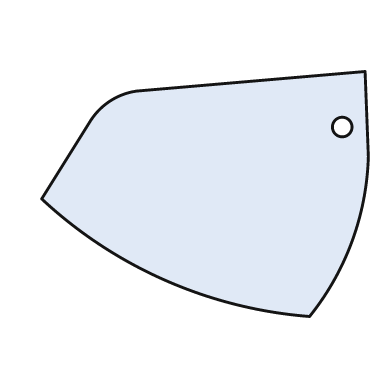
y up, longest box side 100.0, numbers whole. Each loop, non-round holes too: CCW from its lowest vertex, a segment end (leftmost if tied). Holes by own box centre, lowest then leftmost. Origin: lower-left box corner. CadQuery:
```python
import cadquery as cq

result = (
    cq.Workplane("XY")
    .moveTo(82.0, 0.0)
    .threePointArc((95.0, 23.0), (100.0, 49.0))
    .lineTo(99.0, 75.0)
    .lineTo(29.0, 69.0)
    .threePointArc((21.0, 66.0), (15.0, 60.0))
    .lineTo(0.0, 36.0)
    .threePointArc((38.0, 11.0), (82.0, 0.0))
    .close()
    .moveTo(92.0, 58.0)
    .circle(3.0)
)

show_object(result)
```